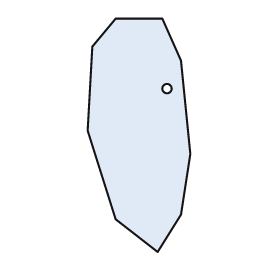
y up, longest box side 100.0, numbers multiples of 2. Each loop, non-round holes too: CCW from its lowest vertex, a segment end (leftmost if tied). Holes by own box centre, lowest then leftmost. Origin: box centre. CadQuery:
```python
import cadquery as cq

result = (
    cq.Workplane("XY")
    .moveTo(8.0, -50.0)
    .lineTo(18.0, -34.0)
    .lineTo(22.0, -8.0)
    .lineTo(18.0, 32.0)
    .lineTo(10.0, 50.0)
    .lineTo(-10.0, 50.0)
    .lineTo(-20.0, 38.0)
    .lineTo(-22.0, 2.0)
    .lineTo(-10.0, -36.0)
    .close()
    .moveTo(12.0, 20.0)
    .circle(2.0)
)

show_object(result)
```